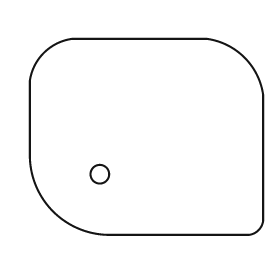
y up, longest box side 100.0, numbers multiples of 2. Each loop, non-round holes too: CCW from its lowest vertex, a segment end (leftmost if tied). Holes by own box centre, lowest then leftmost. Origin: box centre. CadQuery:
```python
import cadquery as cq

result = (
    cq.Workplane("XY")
    .moveTo(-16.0, -42.0)
    .lineTo(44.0, -42.0)
    .threePointArc((48.0, -40.0), (50.0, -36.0))
    .lineTo(50.0, 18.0)
    .threePointArc((42.0, 34.0), (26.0, 42.0))
    .lineTo(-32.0, 42.0)
    .threePointArc((-44.0, 36.0), (-50.0, 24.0))
    .lineTo(-50.0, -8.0)
    .threePointArc((-40.0, -32.0), (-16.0, -42.0))
    .close()
    .moveTo(-20.0, -16.0)
    .circle(4.0)
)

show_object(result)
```